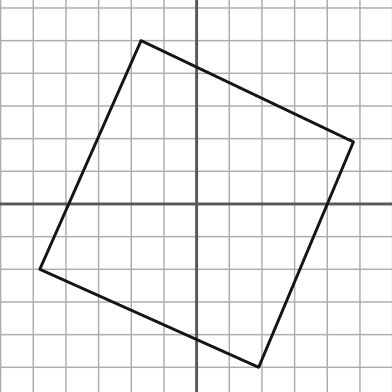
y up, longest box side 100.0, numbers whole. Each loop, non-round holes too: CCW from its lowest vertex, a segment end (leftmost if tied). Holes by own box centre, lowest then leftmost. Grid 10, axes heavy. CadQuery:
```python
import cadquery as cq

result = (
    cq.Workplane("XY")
    .moveTo(19.0, -50.0)
    .lineTo(48.0, 19.0)
    .lineTo(-17.0, 50.0)
    .lineTo(-48.0, -20.0)
    .close()
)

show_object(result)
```